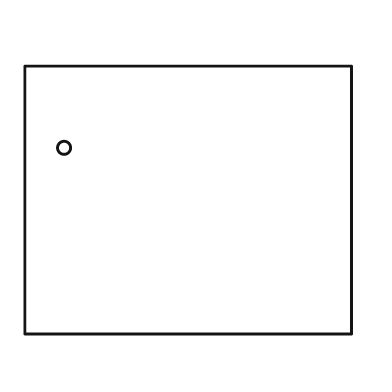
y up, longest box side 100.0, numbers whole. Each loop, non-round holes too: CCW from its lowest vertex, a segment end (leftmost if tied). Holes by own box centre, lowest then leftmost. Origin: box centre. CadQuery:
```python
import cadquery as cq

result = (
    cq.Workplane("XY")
    .moveTo(-50.0, -41.0)
    .lineTo(50.0, -41.0)
    .lineTo(50.0, 41.0)
    .lineTo(-50.0, 41.0)
    .close()
    .moveTo(-38.0, 16.0)
    .circle(2.0)
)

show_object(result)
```